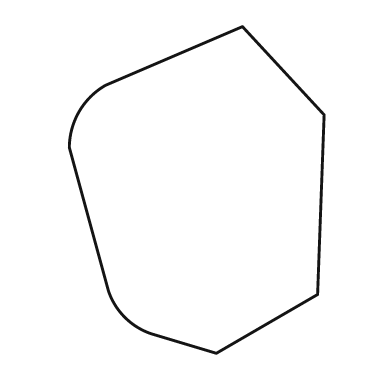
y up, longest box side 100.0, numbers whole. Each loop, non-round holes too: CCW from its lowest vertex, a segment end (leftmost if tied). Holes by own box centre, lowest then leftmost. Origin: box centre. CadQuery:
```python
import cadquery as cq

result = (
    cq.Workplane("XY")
    .moveTo(6.0, -50.0)
    .lineTo(37.0, -32.0)
    .lineTo(39.0, 23.0)
    .lineTo(14.0, 50.0)
    .lineTo(-28.0, 32.0)
    .threePointArc((-36.0, 24.0), (-39.0, 13.0))
    .lineTo(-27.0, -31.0)
    .threePointArc((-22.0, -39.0), (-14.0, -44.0))
    .close()
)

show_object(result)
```